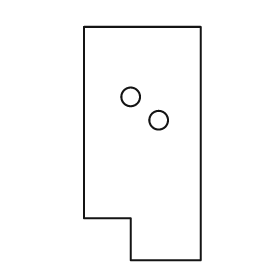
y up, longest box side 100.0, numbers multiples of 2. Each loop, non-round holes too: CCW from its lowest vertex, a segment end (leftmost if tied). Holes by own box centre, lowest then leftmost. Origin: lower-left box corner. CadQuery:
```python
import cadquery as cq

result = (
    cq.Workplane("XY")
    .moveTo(20.0, 0.0)
    .lineTo(50.0, 0.0)
    .lineTo(50.0, 100.0)
    .lineTo(0.0, 100.0)
    .lineTo(0.0, 18.0)
    .lineTo(20.0, 18.0)
    .close()
    .moveTo(32.0, 60.0)
    .circle(4.0)
    .moveTo(20.0, 70.0)
    .circle(4.0)
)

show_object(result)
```